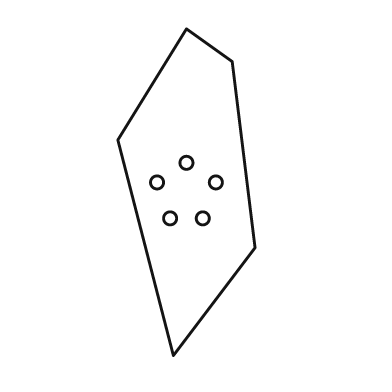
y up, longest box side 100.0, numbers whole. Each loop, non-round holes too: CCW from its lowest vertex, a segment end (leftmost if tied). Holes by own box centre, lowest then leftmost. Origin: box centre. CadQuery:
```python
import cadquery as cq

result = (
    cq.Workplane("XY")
    .moveTo(-4.0, -50.0)
    .lineTo(21.0, -17.0)
    .lineTo(14.0, 40.0)
    .lineTo(0.0, 50.0)
    .lineTo(-21.0, 16.0)
    .close()
    .moveTo(-5.0, -8.0)
    .circle(2.0)
    .moveTo(5.0, -8.0)
    .circle(2.0)
    .moveTo(-9.0, 3.0)
    .circle(2.0)
    .moveTo(9.0, 3.0)
    .circle(2.0)
    .moveTo(0.0, 9.0)
    .circle(2.0)
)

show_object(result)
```